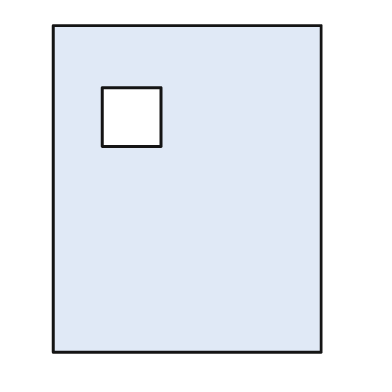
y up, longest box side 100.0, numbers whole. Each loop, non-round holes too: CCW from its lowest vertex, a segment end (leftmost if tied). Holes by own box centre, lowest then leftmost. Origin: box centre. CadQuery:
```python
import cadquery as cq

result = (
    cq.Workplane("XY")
    .moveTo(-41.0, -50.0)
    .lineTo(41.0, -50.0)
    .lineTo(41.0, 50.0)
    .lineTo(-41.0, 50.0)
    .close()
    .moveTo(-26.0, 13.0)
    .lineTo(-8.0, 13.0)
    .lineTo(-8.0, 31.0)
    .lineTo(-26.0, 31.0)
    .close()
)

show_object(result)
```